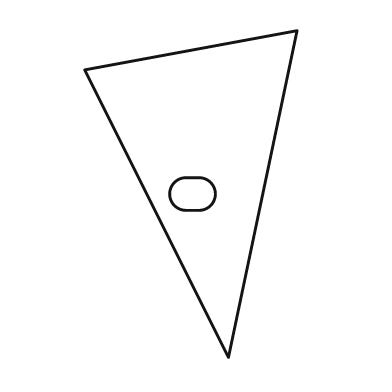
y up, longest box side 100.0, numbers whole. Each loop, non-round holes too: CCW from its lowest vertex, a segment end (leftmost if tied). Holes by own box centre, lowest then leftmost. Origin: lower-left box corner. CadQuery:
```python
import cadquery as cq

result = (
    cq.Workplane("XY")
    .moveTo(44.0, 0.0)
    .lineTo(65.0, 100.0)
    .lineTo(0.0, 88.0)
    .close()
    .moveTo(31.0, 45.0)
    .lineTo(35.0, 45.0)
    .threePointArc((40.0, 50.0), (35.0, 55.0))
    .lineTo(31.0, 55.0)
    .threePointArc((26.0, 50.0), (31.0, 45.0))
    .close()
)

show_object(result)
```